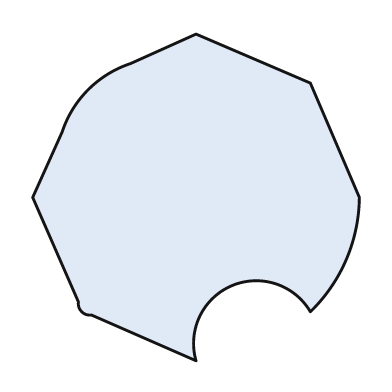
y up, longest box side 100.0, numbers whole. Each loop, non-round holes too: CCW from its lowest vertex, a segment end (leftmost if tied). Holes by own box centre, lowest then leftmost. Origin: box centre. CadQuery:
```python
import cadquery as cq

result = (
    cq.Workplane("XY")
    .moveTo(0.0, -50.0)
    .threePointArc((11.0, -27.0), (35.0, -35.0))
    .threePointArc((46.0, -19.0), (50.0, 0.0))
    .lineTo(35.0, 35.0)
    .lineTo(0.0, 50.0)
    .lineTo(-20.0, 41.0)
    .threePointArc((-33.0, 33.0), (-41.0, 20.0))
    .lineTo(-50.0, 0.0)
    .lineTo(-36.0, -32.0)
    .threePointArc((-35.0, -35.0), (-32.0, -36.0))
    .close()
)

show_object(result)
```